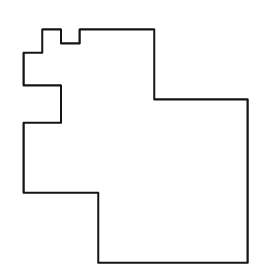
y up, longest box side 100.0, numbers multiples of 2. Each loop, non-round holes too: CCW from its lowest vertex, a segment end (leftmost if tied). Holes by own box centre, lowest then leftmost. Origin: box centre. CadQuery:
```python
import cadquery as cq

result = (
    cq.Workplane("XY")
    .moveTo(-16.0, -50.0)
    .lineTo(48.0, -50.0)
    .lineTo(48.0, 20.0)
    .lineTo(8.0, 20.0)
    .lineTo(8.0, 50.0)
    .lineTo(-24.0, 50.0)
    .lineTo(-24.0, 44.0)
    .lineTo(-32.0, 44.0)
    .lineTo(-32.0, 50.0)
    .lineTo(-40.0, 50.0)
    .lineTo(-40.0, 40.0)
    .lineTo(-48.0, 40.0)
    .lineTo(-48.0, 26.0)
    .lineTo(-32.0, 26.0)
    .lineTo(-32.0, 10.0)
    .lineTo(-48.0, 10.0)
    .lineTo(-48.0, -20.0)
    .lineTo(-16.0, -20.0)
    .close()
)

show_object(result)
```